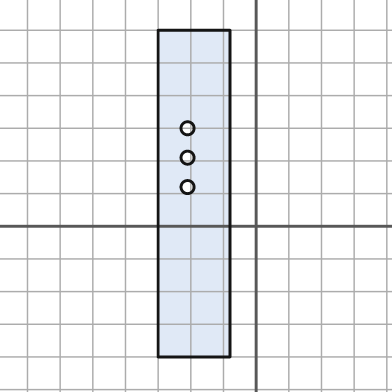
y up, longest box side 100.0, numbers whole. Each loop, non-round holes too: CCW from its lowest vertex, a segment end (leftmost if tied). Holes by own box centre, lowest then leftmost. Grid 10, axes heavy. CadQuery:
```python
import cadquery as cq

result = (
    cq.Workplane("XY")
    .moveTo(-30.0, -40.0)
    .lineTo(-8.0, -40.0)
    .lineTo(-8.0, 60.0)
    .lineTo(-30.0, 60.0)
    .close()
    .moveTo(-21.0, 12.0)
    .circle(2.0)
    .moveTo(-21.0, 21.0)
    .circle(2.0)
    .moveTo(-21.0, 30.0)
    .circle(2.0)
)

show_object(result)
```